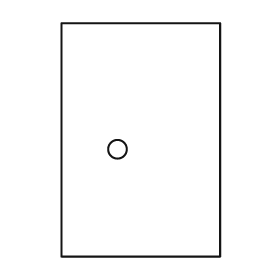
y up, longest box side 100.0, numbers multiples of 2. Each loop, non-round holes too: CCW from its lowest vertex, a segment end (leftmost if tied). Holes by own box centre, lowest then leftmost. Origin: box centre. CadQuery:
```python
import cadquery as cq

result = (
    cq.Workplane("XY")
    .moveTo(-34.0, -50.0)
    .lineTo(34.0, -50.0)
    .lineTo(34.0, 50.0)
    .lineTo(-34.0, 50.0)
    .close()
    .moveTo(-10.0, -4.0)
    .circle(4.0)
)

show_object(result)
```